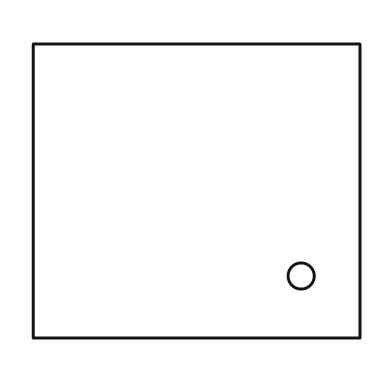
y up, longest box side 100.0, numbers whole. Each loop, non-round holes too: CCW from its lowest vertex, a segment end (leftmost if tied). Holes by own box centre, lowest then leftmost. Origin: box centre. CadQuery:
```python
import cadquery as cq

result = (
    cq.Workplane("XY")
    .moveTo(-50.0, -45.0)
    .lineTo(50.0, -45.0)
    .lineTo(50.0, 45.0)
    .lineTo(-50.0, 45.0)
    .close()
    .moveTo(32.0, -26.0)
    .circle(4.0)
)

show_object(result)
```